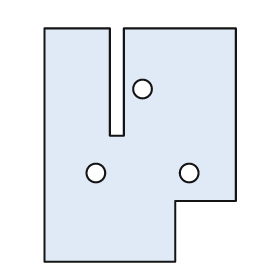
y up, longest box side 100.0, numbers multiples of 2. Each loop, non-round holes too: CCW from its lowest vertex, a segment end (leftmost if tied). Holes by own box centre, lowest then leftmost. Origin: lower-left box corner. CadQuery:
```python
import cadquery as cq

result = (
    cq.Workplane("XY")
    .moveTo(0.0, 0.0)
    .lineTo(56.0, 0.0)
    .lineTo(56.0, 26.0)
    .lineTo(82.0, 26.0)
    .lineTo(82.0, 100.0)
    .lineTo(34.0, 100.0)
    .lineTo(34.0, 54.0)
    .lineTo(28.0, 54.0)
    .lineTo(28.0, 100.0)
    .lineTo(0.0, 100.0)
    .close()
    .moveTo(22.0, 38.0)
    .circle(4.0)
    .moveTo(62.0, 38.0)
    .circle(4.0)
    .moveTo(42.0, 74.0)
    .circle(4.0)
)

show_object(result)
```